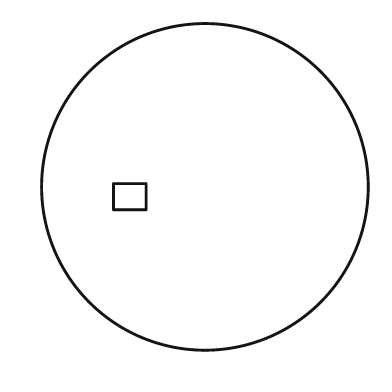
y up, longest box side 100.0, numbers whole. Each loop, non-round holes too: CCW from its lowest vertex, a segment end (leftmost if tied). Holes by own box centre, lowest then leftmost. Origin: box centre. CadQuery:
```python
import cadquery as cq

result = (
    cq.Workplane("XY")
    .moveTo(0.0, 0.0)
    .circle(50.0)
    .moveTo(-28.0, -7.0)
    .lineTo(-18.0, -7.0)
    .lineTo(-18.0, 1.0)
    .lineTo(-28.0, 1.0)
    .close()
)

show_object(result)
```